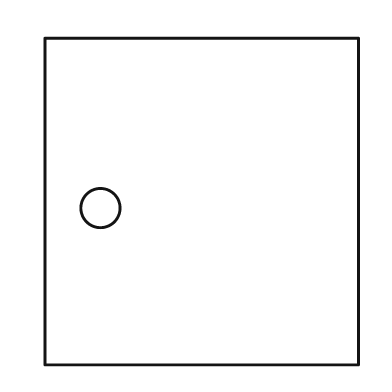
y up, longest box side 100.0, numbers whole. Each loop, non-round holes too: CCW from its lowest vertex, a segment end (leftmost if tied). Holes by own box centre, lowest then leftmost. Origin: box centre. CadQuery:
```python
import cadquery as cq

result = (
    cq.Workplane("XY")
    .moveTo(-48.0, -50.0)
    .lineTo(48.0, -50.0)
    .lineTo(48.0, 50.0)
    .lineTo(-48.0, 50.0)
    .close()
    .moveTo(-31.0, -2.0)
    .circle(6.0)
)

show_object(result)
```